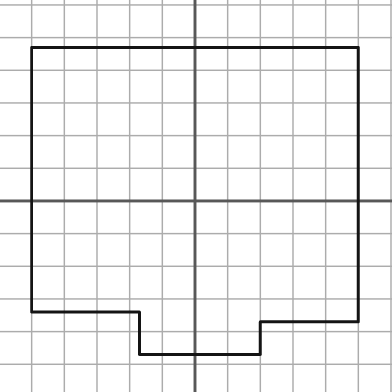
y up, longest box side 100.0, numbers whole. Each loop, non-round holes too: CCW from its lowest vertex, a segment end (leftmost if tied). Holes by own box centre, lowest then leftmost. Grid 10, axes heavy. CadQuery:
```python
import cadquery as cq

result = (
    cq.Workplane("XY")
    .moveTo(-17.0, -47.0)
    .lineTo(20.0, -47.0)
    .lineTo(20.0, -37.0)
    .lineTo(50.0, -37.0)
    .lineTo(50.0, 47.0)
    .lineTo(-50.0, 47.0)
    .lineTo(-50.0, -34.0)
    .lineTo(-17.0, -34.0)
    .close()
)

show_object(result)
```